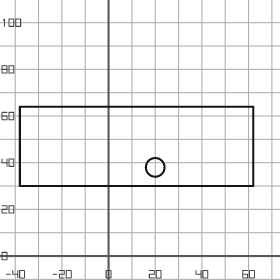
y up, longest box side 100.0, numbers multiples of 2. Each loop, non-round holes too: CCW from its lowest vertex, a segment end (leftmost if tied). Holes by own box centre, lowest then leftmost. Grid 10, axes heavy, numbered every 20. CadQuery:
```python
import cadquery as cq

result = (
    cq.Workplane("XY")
    .moveTo(-38.0, 30.0)
    .lineTo(62.0, 30.0)
    .lineTo(62.0, 64.0)
    .lineTo(-38.0, 64.0)
    .close()
    .moveTo(20.0, 38.0)
    .circle(4.0)
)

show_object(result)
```